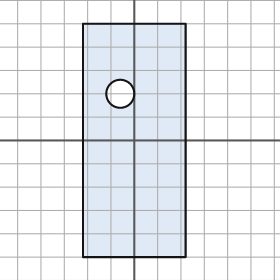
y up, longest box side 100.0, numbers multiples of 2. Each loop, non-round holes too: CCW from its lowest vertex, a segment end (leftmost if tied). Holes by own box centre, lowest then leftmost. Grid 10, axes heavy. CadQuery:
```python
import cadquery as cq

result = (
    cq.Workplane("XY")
    .moveTo(-22.0, -50.0)
    .lineTo(22.0, -50.0)
    .lineTo(22.0, 50.0)
    .lineTo(-22.0, 50.0)
    .close()
    .moveTo(-6.0, 20.0)
    .circle(6.0)
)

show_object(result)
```